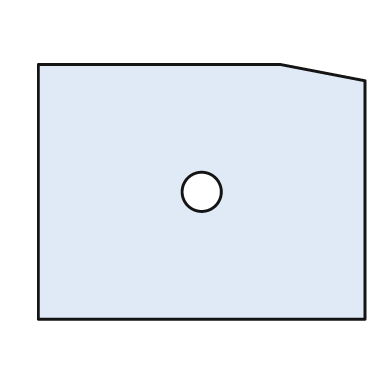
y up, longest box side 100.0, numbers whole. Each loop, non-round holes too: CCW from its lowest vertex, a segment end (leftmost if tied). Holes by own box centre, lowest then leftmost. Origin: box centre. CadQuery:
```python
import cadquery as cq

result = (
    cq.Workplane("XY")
    .moveTo(-50.0, -39.0)
    .lineTo(50.0, -39.0)
    .lineTo(50.0, 34.0)
    .lineTo(24.0, 39.0)
    .lineTo(-50.0, 39.0)
    .close()
    .moveTo(0.0, 0.0)
    .circle(6.0)
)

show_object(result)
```